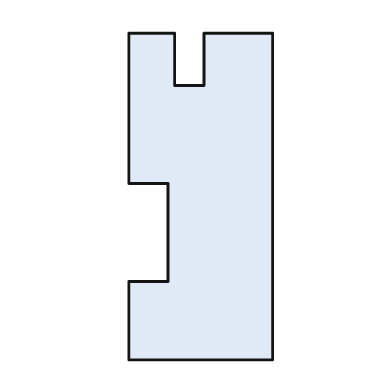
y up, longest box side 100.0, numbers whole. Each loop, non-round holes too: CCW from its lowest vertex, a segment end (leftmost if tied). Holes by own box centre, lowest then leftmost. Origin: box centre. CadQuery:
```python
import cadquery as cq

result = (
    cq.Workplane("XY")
    .moveTo(-22.0, -50.0)
    .lineTo(22.0, -50.0)
    .lineTo(22.0, 50.0)
    .lineTo(1.0, 50.0)
    .lineTo(1.0, 34.0)
    .lineTo(-8.0, 34.0)
    .lineTo(-8.0, 50.0)
    .lineTo(-22.0, 50.0)
    .lineTo(-22.0, 4.0)
    .lineTo(-10.0, 4.0)
    .lineTo(-10.0, -26.0)
    .lineTo(-22.0, -26.0)
    .close()
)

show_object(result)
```